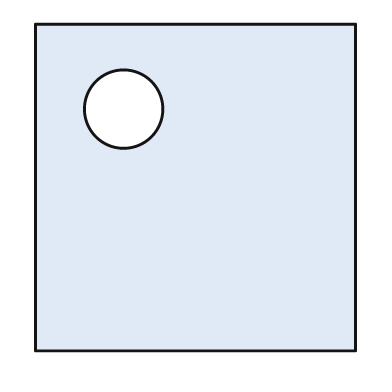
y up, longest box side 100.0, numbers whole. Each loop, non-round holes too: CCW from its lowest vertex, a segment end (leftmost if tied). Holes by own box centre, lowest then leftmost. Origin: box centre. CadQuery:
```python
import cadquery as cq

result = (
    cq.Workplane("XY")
    .moveTo(-49.0, -50.0)
    .lineTo(49.0, -50.0)
    .lineTo(49.0, 50.0)
    .lineTo(-49.0, 50.0)
    .close()
    .moveTo(-22.0, 24.0)
    .circle(12.0)
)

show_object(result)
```